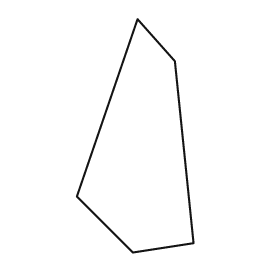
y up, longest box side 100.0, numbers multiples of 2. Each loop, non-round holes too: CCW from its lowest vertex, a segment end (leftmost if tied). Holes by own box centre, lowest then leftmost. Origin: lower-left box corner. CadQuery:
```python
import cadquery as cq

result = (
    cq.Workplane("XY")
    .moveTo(24.0, 0.0)
    .lineTo(50.0, 4.0)
    .lineTo(42.0, 82.0)
    .lineTo(26.0, 100.0)
    .lineTo(0.0, 24.0)
    .close()
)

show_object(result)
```